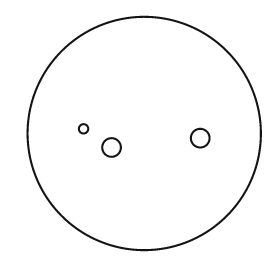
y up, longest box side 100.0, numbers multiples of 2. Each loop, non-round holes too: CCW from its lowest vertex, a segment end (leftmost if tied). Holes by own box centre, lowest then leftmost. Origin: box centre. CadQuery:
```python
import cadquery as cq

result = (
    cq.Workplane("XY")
    .moveTo(0.0, 0.0)
    .circle(50.0)
    .moveTo(-14.0, -6.0)
    .circle(4.0)
    .moveTo(24.0, -2.0)
    .circle(4.0)
    .moveTo(-26.0, 2.0)
    .circle(2.0)
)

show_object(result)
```